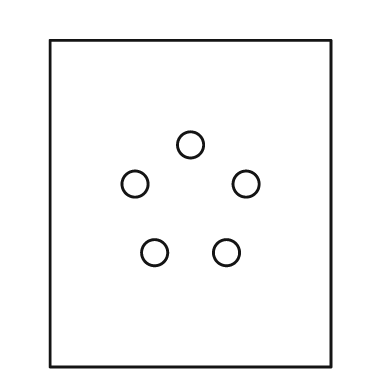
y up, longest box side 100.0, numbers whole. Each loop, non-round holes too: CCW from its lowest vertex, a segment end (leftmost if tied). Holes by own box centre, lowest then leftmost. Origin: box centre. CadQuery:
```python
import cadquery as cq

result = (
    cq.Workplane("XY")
    .moveTo(-43.0, -50.0)
    .lineTo(43.0, -50.0)
    .lineTo(43.0, 50.0)
    .lineTo(-43.0, 50.0)
    .close()
    .moveTo(-11.0, -15.0)
    .circle(4.0)
    .moveTo(11.0, -15.0)
    .circle(4.0)
    .moveTo(-17.0, 6.0)
    .circle(4.0)
    .moveTo(17.0, 6.0)
    .circle(4.0)
    .moveTo(0.0, 18.0)
    .circle(4.0)
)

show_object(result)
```